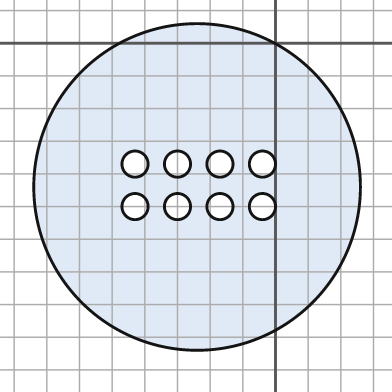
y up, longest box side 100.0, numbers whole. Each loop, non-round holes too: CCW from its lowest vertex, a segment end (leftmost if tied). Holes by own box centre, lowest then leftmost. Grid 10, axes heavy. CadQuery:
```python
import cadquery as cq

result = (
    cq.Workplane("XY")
    .moveTo(-24.0, -44.0)
    .circle(50.0)
    .moveTo(-43.0, -50.0)
    .circle(4.0)
    .moveTo(-30.0, -50.0)
    .circle(4.0)
    .moveTo(-17.0, -50.0)
    .circle(4.0)
    .moveTo(-4.0, -50.0)
    .circle(4.0)
    .moveTo(-43.0, -37.0)
    .circle(4.0)
    .moveTo(-30.0, -37.0)
    .circle(4.0)
    .moveTo(-17.0, -37.0)
    .circle(4.0)
    .moveTo(-4.0, -37.0)
    .circle(4.0)
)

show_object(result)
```